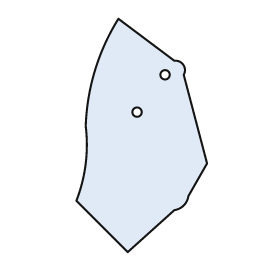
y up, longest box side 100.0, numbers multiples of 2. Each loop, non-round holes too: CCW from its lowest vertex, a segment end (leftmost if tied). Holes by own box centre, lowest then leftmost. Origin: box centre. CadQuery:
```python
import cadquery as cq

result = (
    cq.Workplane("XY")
    .moveTo(-6.0, -50.0)
    .lineTo(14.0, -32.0)
    .threePointArc((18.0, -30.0), (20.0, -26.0))
    .lineTo(28.0, -12.0)
    .lineTo(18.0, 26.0)
    .threePointArc((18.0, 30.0), (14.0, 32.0))
    .lineTo(-10.0, 50.0)
    .threePointArc((-20.0, 28.0), (-24.0, 4.0))
    .threePointArc((-24.0, -12.0), (-28.0, -28.0))
    .close()
    .moveTo(-2.0, 10.0)
    .circle(2.0)
    .moveTo(10.0, 26.0)
    .circle(2.0)
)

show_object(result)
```